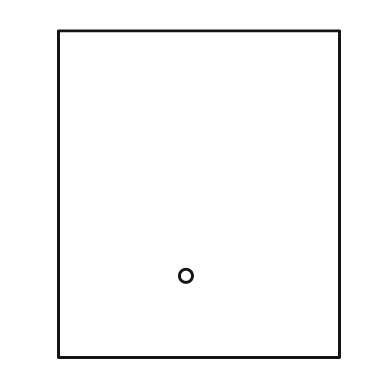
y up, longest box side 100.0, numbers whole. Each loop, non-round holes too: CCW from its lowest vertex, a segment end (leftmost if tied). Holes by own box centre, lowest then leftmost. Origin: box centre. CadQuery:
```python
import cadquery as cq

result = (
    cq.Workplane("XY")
    .moveTo(-43.0, -50.0)
    .lineTo(43.0, -50.0)
    .lineTo(43.0, 50.0)
    .lineTo(-43.0, 50.0)
    .close()
    .moveTo(-4.0, -25.0)
    .circle(2.0)
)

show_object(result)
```